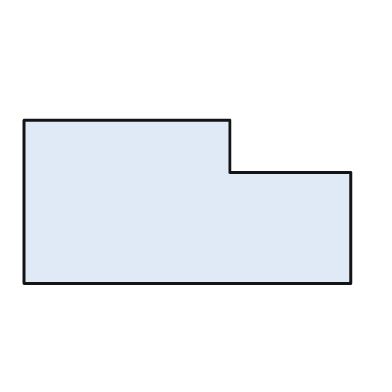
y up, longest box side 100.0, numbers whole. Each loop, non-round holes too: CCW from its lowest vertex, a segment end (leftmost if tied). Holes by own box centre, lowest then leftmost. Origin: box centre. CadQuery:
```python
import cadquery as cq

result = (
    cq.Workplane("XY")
    .moveTo(-50.0, -25.0)
    .lineTo(50.0, -25.0)
    .lineTo(50.0, 9.0)
    .lineTo(13.0, 9.0)
    .lineTo(13.0, 25.0)
    .lineTo(-50.0, 25.0)
    .close()
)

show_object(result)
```